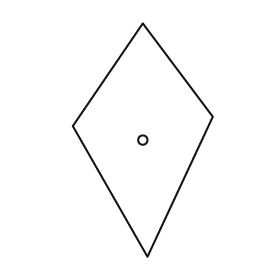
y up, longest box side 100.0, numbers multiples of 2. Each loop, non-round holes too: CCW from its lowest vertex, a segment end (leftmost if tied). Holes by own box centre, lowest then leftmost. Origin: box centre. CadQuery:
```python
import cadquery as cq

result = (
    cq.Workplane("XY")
    .moveTo(2.0, -50.0)
    .lineTo(30.0, 10.0)
    .lineTo(0.0, 50.0)
    .lineTo(-30.0, 6.0)
    .close()
    .moveTo(0.0, 0.0)
    .circle(2.0)
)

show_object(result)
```